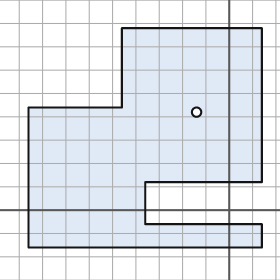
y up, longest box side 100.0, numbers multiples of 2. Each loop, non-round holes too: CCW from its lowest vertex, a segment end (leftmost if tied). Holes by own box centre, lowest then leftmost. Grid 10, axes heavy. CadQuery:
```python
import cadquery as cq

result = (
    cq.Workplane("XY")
    .moveTo(-86.0, -16.0)
    .lineTo(14.0, -16.0)
    .lineTo(14.0, -6.0)
    .lineTo(-36.0, -6.0)
    .lineTo(-36.0, 12.0)
    .lineTo(14.0, 12.0)
    .lineTo(14.0, 78.0)
    .lineTo(-46.0, 78.0)
    .lineTo(-46.0, 44.0)
    .lineTo(-86.0, 44.0)
    .close()
    .moveTo(-14.0, 42.0)
    .circle(2.0)
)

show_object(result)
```